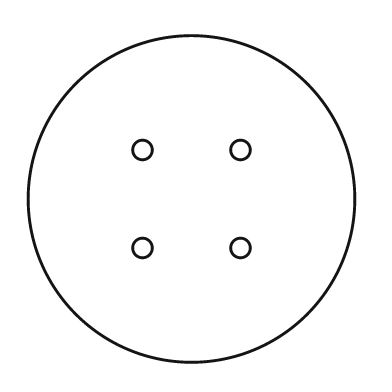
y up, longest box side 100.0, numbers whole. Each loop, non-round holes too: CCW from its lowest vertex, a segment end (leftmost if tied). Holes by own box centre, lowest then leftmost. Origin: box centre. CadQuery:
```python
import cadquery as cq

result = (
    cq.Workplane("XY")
    .moveTo(0.0, 0.0)
    .circle(50.0)
    .moveTo(-15.0, -15.0)
    .circle(3.0)
    .moveTo(15.0, -15.0)
    .circle(3.0)
    .moveTo(-15.0, 15.0)
    .circle(3.0)
    .moveTo(15.0, 15.0)
    .circle(3.0)
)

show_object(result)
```